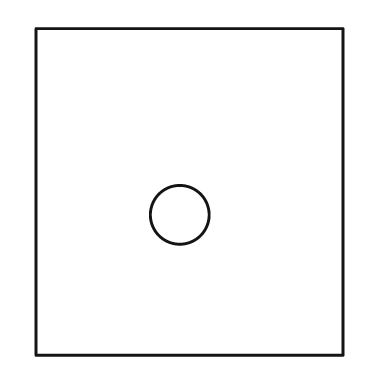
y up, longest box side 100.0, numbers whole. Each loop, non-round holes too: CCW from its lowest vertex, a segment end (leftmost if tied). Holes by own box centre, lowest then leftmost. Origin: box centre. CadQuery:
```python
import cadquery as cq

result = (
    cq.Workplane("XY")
    .moveTo(-47.0, -50.0)
    .lineTo(47.0, -50.0)
    .lineTo(47.0, 50.0)
    .lineTo(-47.0, 50.0)
    .close()
    .moveTo(-3.0, -7.0)
    .circle(9.0)
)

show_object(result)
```